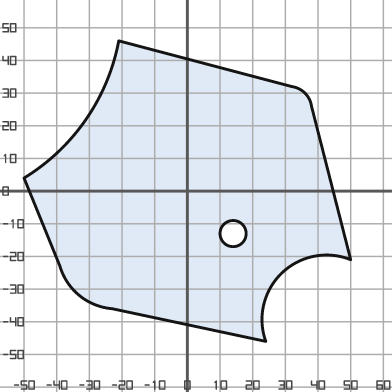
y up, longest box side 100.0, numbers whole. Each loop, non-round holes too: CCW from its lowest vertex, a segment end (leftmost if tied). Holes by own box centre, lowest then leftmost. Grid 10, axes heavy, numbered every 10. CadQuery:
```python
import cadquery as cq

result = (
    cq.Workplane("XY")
    .moveTo(24.0, -46.0)
    .threePointArc((29.0, -25.0), (50.0, -21.0))
    .lineTo(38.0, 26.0)
    .threePointArc((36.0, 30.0), (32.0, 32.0))
    .lineTo(-21.0, 46.0)
    .threePointArc((-31.0, 22.0), (-50.0, 4.0))
    .lineTo(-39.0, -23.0)
    .threePointArc((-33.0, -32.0), (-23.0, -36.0))
    .close()
    .moveTo(14.0, -13.0)
    .circle(4.0)
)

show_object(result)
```